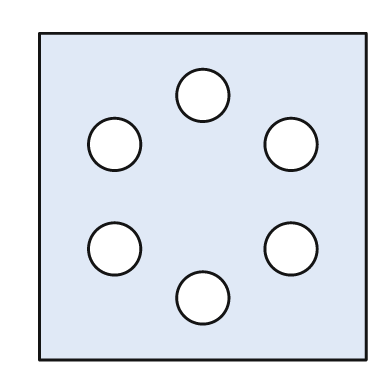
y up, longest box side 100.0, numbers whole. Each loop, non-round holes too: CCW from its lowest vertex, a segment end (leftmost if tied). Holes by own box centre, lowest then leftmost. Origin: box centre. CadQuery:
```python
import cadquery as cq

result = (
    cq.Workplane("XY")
    .moveTo(-50.0, -50.0)
    .lineTo(50.0, -50.0)
    .lineTo(50.0, 50.0)
    .lineTo(-50.0, 50.0)
    .close()
    .moveTo(0.0, -31.0)
    .circle(8.0)
    .moveTo(-27.0, -16.0)
    .circle(8.0)
    .moveTo(27.0, -16.0)
    .circle(8.0)
    .moveTo(-27.0, 16.0)
    .circle(8.0)
    .moveTo(27.0, 16.0)
    .circle(8.0)
    .moveTo(0.0, 31.0)
    .circle(8.0)
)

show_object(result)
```